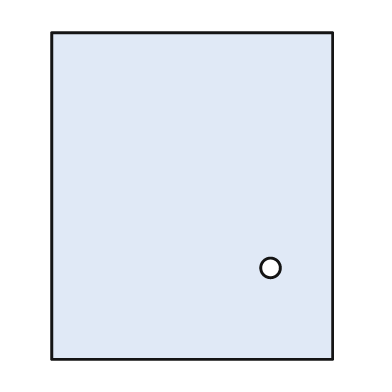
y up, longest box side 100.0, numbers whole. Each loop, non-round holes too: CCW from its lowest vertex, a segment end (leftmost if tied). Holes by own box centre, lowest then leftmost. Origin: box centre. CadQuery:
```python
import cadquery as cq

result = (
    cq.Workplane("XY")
    .moveTo(-43.0, -50.0)
    .lineTo(43.0, -50.0)
    .lineTo(43.0, 50.0)
    .lineTo(-43.0, 50.0)
    .close()
    .moveTo(24.0, -22.0)
    .circle(3.0)
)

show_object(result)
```